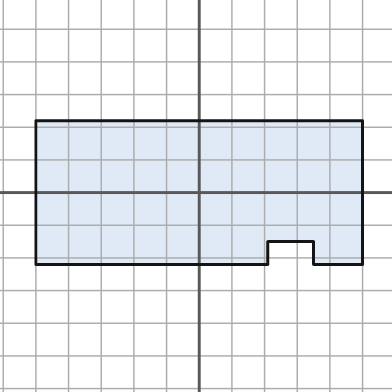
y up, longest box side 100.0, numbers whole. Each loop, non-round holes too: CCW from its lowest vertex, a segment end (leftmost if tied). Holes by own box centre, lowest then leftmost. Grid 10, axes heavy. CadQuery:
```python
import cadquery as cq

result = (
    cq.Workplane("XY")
    .moveTo(-50.0, -22.0)
    .lineTo(21.0, -22.0)
    .lineTo(21.0, -15.0)
    .lineTo(35.0, -15.0)
    .lineTo(35.0, -22.0)
    .lineTo(50.0, -22.0)
    .lineTo(50.0, 22.0)
    .lineTo(-50.0, 22.0)
    .close()
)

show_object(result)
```